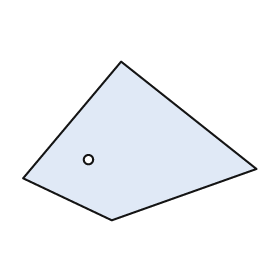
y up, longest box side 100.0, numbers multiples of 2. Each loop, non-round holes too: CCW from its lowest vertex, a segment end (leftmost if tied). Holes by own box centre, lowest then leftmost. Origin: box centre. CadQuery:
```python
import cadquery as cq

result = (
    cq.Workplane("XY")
    .moveTo(-12.0, -34.0)
    .lineTo(50.0, -12.0)
    .lineTo(-8.0, 34.0)
    .lineTo(-50.0, -16.0)
    .close()
    .moveTo(-22.0, -8.0)
    .circle(2.0)
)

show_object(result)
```